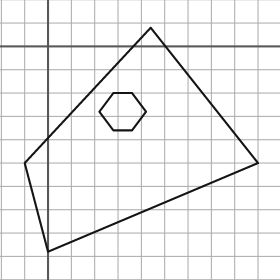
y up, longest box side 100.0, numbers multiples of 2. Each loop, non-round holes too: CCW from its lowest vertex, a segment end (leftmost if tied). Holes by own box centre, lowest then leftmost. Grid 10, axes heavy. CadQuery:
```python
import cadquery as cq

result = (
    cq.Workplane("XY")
    .moveTo(0.0, -88.0)
    .lineTo(90.0, -50.0)
    .lineTo(44.0, 8.0)
    .lineTo(-10.0, -50.0)
    .close()
    .moveTo(28.0, -36.0)
    .lineTo(36.0, -36.0)
    .lineTo(42.0, -28.0)
    .lineTo(36.0, -20.0)
    .lineTo(28.0, -20.0)
    .lineTo(22.0, -28.0)
    .close()
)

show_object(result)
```